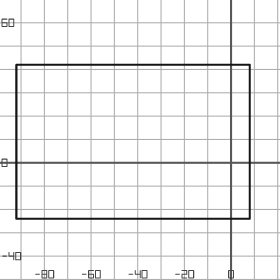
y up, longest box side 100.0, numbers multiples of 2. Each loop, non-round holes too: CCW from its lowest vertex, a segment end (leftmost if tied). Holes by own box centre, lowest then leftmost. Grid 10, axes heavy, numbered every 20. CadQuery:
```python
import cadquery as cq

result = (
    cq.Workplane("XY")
    .moveTo(-92.0, -24.0)
    .lineTo(8.0, -24.0)
    .lineTo(8.0, 42.0)
    .lineTo(-92.0, 42.0)
    .close()
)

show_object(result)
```